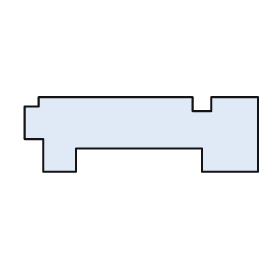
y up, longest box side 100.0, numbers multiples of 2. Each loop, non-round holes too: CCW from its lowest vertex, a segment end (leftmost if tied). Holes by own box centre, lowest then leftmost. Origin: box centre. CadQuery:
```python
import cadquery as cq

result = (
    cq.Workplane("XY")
    .moveTo(-42.0, -16.0)
    .lineTo(-28.0, -16.0)
    .lineTo(-28.0, -6.0)
    .lineTo(26.0, -6.0)
    .lineTo(26.0, -16.0)
    .lineTo(50.0, -16.0)
    .lineTo(50.0, 16.0)
    .lineTo(30.0, 16.0)
    .lineTo(30.0, 10.0)
    .lineTo(22.0, 10.0)
    .lineTo(22.0, 16.0)
    .lineTo(-44.0, 16.0)
    .lineTo(-44.0, 12.0)
    .lineTo(-50.0, 12.0)
    .lineTo(-50.0, -2.0)
    .lineTo(-42.0, -2.0)
    .close()
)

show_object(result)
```